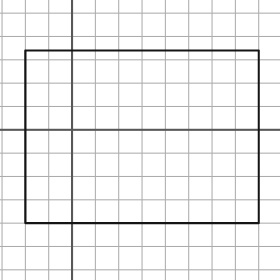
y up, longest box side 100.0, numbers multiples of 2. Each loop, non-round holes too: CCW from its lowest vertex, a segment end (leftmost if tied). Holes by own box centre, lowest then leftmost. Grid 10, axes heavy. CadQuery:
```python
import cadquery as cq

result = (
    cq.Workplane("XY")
    .moveTo(-20.0, -40.0)
    .lineTo(80.0, -40.0)
    .lineTo(80.0, 34.0)
    .lineTo(-20.0, 34.0)
    .close()
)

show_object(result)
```